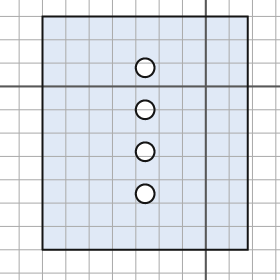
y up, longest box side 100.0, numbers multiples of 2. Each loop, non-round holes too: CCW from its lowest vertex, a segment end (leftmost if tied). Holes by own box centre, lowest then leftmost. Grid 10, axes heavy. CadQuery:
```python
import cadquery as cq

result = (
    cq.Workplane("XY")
    .moveTo(-70.0, -70.0)
    .lineTo(18.0, -70.0)
    .lineTo(18.0, 30.0)
    .lineTo(-70.0, 30.0)
    .close()
    .moveTo(-26.0, -46.0)
    .circle(4.0)
    .moveTo(-26.0, -28.0)
    .circle(4.0)
    .moveTo(-26.0, -10.0)
    .circle(4.0)
    .moveTo(-26.0, 8.0)
    .circle(4.0)
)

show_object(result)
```